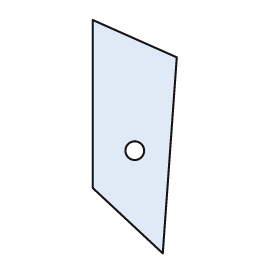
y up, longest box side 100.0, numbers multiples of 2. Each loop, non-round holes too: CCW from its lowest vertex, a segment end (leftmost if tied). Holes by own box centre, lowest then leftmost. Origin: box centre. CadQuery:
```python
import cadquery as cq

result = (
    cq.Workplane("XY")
    .moveTo(12.0, -50.0)
    .lineTo(18.0, 34.0)
    .lineTo(-18.0, 50.0)
    .lineTo(-18.0, -22.0)
    .close()
    .moveTo(0.0, -6.0)
    .circle(4.0)
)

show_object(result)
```